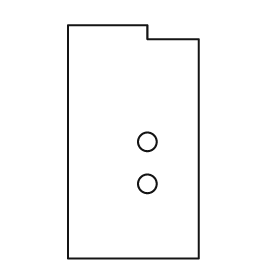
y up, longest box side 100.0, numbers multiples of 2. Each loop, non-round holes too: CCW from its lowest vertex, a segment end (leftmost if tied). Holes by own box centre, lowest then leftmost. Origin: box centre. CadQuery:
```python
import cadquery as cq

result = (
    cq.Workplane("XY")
    .moveTo(-28.0, -50.0)
    .lineTo(28.0, -50.0)
    .lineTo(28.0, 44.0)
    .lineTo(6.0, 44.0)
    .lineTo(6.0, 50.0)
    .lineTo(-28.0, 50.0)
    .close()
    .moveTo(6.0, -18.0)
    .circle(4.0)
    .moveTo(6.0, 0.0)
    .circle(4.0)
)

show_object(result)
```